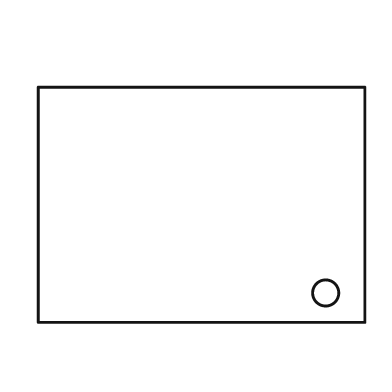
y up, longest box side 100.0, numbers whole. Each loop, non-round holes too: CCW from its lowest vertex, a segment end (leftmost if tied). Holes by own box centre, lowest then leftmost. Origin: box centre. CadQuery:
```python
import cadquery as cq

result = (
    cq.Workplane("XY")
    .moveTo(-50.0, -36.0)
    .lineTo(50.0, -36.0)
    .lineTo(50.0, 36.0)
    .lineTo(-50.0, 36.0)
    .close()
    .moveTo(38.0, -27.0)
    .circle(4.0)
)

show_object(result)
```